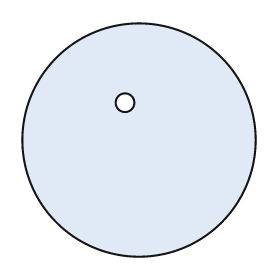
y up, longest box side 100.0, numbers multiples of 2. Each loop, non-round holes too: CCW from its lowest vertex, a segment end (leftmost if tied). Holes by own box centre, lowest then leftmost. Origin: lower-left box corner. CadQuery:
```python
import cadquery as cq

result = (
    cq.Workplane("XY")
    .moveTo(50.0, 50.0)
    .circle(50.0)
    .moveTo(44.0, 66.0)
    .circle(4.0)
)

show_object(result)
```